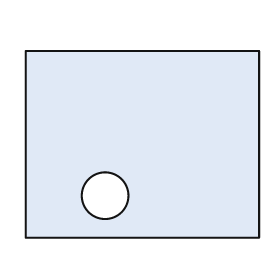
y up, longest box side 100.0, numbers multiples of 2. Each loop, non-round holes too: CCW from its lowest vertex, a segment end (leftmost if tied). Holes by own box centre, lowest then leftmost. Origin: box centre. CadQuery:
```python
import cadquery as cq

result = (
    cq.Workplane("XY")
    .moveTo(-50.0, -40.0)
    .lineTo(50.0, -40.0)
    .lineTo(50.0, 40.0)
    .lineTo(-50.0, 40.0)
    .close()
    .moveTo(-16.0, -22.0)
    .circle(10.0)
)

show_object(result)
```